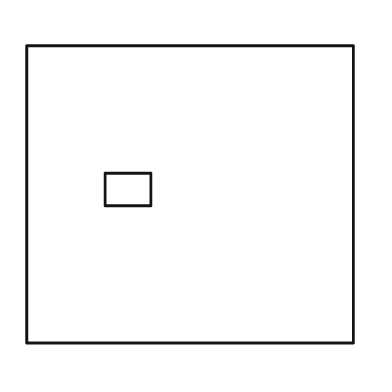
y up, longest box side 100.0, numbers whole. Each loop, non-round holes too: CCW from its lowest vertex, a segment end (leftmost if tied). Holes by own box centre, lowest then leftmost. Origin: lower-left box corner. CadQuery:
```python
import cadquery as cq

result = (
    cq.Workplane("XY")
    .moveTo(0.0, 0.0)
    .lineTo(100.0, 0.0)
    .lineTo(100.0, 91.0)
    .lineTo(0.0, 91.0)
    .close()
    .moveTo(24.0, 42.0)
    .lineTo(38.0, 42.0)
    .lineTo(38.0, 52.0)
    .lineTo(24.0, 52.0)
    .close()
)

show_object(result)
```